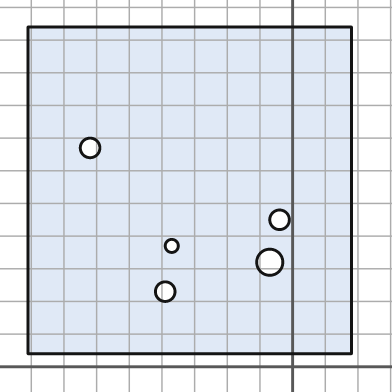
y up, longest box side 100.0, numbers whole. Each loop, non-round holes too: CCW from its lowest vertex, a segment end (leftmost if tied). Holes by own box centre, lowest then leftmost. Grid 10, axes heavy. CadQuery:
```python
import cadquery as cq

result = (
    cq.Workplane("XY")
    .moveTo(-81.0, 4.0)
    .lineTo(18.0, 4.0)
    .lineTo(18.0, 104.0)
    .lineTo(-81.0, 104.0)
    .close()
    .moveTo(-39.0, 23.0)
    .circle(3.0)
    .moveTo(-7.0, 32.0)
    .circle(4.0)
    .moveTo(-37.0, 37.0)
    .circle(2.0)
    .moveTo(-4.0, 45.0)
    .circle(3.0)
    .moveTo(-62.0, 67.0)
    .circle(3.0)
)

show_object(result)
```